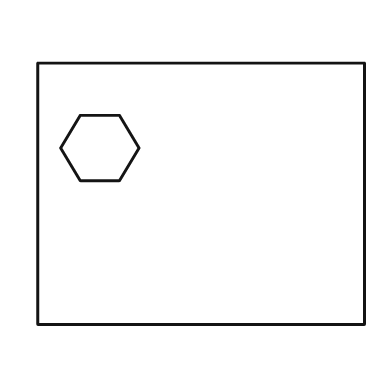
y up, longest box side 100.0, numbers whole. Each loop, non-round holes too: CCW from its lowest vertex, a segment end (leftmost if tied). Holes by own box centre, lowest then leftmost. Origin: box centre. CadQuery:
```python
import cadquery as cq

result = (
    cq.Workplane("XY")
    .moveTo(-50.0, -40.0)
    .lineTo(50.0, -40.0)
    .lineTo(50.0, 40.0)
    .lineTo(-50.0, 40.0)
    .close()
    .moveTo(-37.0, 4.0)
    .lineTo(-25.0, 4.0)
    .lineTo(-19.0, 14.0)
    .lineTo(-25.0, 24.0)
    .lineTo(-37.0, 24.0)
    .lineTo(-43.0, 14.0)
    .close()
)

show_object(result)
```